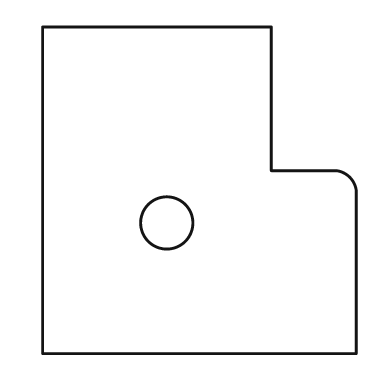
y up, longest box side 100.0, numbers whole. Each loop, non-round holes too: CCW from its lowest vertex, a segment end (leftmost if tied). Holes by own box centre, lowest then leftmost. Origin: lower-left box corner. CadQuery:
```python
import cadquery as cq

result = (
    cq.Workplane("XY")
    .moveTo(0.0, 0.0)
    .lineTo(96.0, 0.0)
    .lineTo(96.0, 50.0)
    .threePointArc((94.0, 54.0), (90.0, 56.0))
    .lineTo(70.0, 56.0)
    .lineTo(70.0, 100.0)
    .lineTo(0.0, 100.0)
    .close()
    .moveTo(38.0, 40.0)
    .circle(8.0)
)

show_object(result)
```